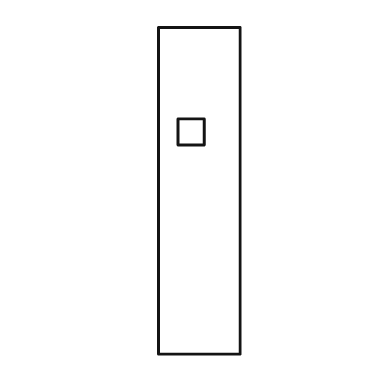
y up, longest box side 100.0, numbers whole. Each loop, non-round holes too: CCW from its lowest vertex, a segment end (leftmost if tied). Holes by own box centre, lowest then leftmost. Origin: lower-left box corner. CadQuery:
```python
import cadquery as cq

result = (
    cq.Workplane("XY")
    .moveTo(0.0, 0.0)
    .lineTo(25.0, 0.0)
    .lineTo(25.0, 100.0)
    .lineTo(0.0, 100.0)
    .close()
    .moveTo(6.0, 64.0)
    .lineTo(14.0, 64.0)
    .lineTo(14.0, 72.0)
    .lineTo(6.0, 72.0)
    .close()
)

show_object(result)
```